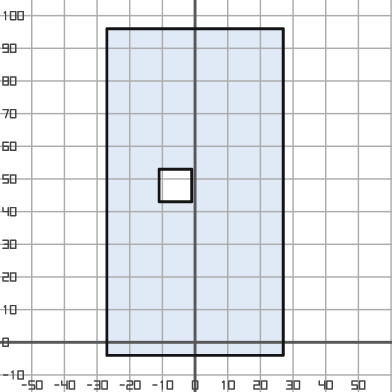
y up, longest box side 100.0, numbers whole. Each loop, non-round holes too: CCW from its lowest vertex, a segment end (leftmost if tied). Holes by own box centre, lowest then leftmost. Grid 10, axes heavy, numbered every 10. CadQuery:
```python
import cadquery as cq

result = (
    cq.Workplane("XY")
    .moveTo(-27.0, -4.0)
    .lineTo(27.0, -4.0)
    .lineTo(27.0, 96.0)
    .lineTo(-27.0, 96.0)
    .close()
    .moveTo(-11.0, 43.0)
    .lineTo(-1.0, 43.0)
    .lineTo(-1.0, 53.0)
    .lineTo(-11.0, 53.0)
    .close()
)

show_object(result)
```